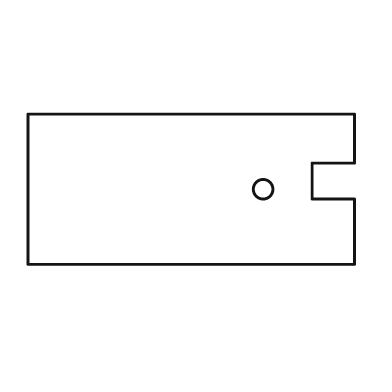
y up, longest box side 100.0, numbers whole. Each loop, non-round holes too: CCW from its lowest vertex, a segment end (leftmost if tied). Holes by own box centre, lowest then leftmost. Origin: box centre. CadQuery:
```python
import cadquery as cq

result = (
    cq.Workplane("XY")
    .moveTo(-50.0, -23.0)
    .lineTo(50.0, -23.0)
    .lineTo(50.0, -3.0)
    .lineTo(37.0, -3.0)
    .lineTo(37.0, 8.0)
    .lineTo(50.0, 8.0)
    .lineTo(50.0, 23.0)
    .lineTo(-50.0, 23.0)
    .close()
    .moveTo(22.0, 0.0)
    .circle(3.0)
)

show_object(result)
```